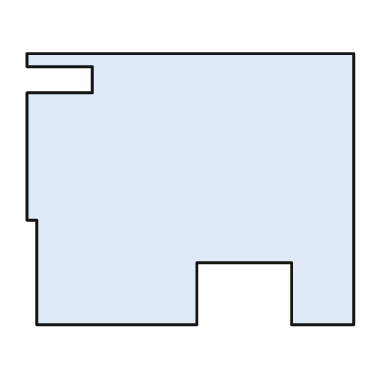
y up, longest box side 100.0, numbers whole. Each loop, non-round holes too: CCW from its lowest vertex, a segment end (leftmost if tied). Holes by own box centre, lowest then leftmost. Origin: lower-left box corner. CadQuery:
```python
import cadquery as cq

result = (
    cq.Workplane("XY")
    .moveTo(3.0, 0.0)
    .lineTo(52.0, 0.0)
    .lineTo(52.0, 19.0)
    .lineTo(81.0, 19.0)
    .lineTo(81.0, 0.0)
    .lineTo(100.0, 0.0)
    .lineTo(100.0, 83.0)
    .lineTo(0.0, 83.0)
    .lineTo(0.0, 79.0)
    .lineTo(20.0, 79.0)
    .lineTo(20.0, 71.0)
    .lineTo(0.0, 71.0)
    .lineTo(0.0, 32.0)
    .lineTo(3.0, 32.0)
    .close()
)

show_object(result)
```